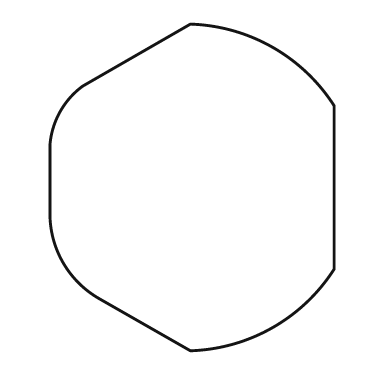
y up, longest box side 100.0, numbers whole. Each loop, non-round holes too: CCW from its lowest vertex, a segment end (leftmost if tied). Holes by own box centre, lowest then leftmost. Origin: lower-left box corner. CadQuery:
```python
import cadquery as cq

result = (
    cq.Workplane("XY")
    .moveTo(43.0, 0.0)
    .threePointArc((68.0, 7.0), (87.0, 25.0))
    .lineTo(87.0, 75.0)
    .threePointArc((68.0, 93.0), (43.0, 100.0))
    .lineTo(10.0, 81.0)
    .threePointArc((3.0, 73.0), (0.0, 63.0))
    .lineTo(0.0, 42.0)
    .threePointArc((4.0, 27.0), (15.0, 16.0))
    .close()
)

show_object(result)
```